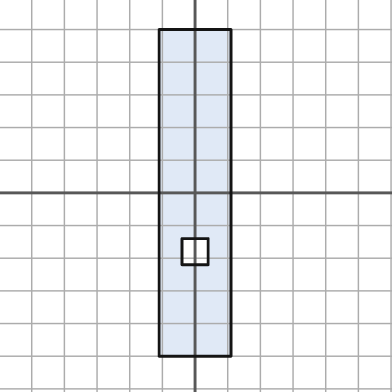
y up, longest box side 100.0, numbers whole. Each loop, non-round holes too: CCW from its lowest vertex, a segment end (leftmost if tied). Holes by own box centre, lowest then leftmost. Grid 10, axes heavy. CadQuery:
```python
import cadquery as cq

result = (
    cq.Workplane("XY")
    .moveTo(-11.0, -50.0)
    .lineTo(11.0, -50.0)
    .lineTo(11.0, 50.0)
    .lineTo(-11.0, 50.0)
    .close()
    .moveTo(-4.0, -22.0)
    .lineTo(4.0, -22.0)
    .lineTo(4.0, -14.0)
    .lineTo(-4.0, -14.0)
    .close()
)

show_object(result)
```